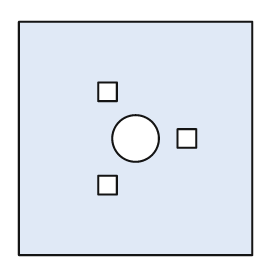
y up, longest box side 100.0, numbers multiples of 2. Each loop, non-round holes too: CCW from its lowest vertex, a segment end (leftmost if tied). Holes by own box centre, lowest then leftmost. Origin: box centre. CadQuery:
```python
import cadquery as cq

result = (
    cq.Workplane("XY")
    .moveTo(-50.0, -50.0)
    .lineTo(50.0, -50.0)
    .lineTo(50.0, 50.0)
    .lineTo(-50.0, 50.0)
    .close()
    .moveTo(-16.0, -24.0)
    .lineTo(-8.0, -24.0)
    .lineTo(-8.0, -16.0)
    .lineTo(-16.0, -16.0)
    .close()
    .moveTo(0.0, 0.0)
    .circle(10.0)
    .moveTo(18.0, -4.0)
    .lineTo(26.0, -4.0)
    .lineTo(26.0, 4.0)
    .lineTo(18.0, 4.0)
    .close()
    .moveTo(-16.0, 16.0)
    .lineTo(-8.0, 16.0)
    .lineTo(-8.0, 24.0)
    .lineTo(-16.0, 24.0)
    .close()
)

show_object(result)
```